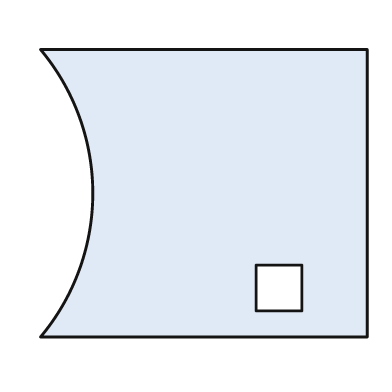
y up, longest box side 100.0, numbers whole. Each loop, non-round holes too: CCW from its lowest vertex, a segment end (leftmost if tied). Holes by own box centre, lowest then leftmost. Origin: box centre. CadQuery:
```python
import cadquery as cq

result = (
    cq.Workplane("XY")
    .moveTo(-50.0, -44.0)
    .lineTo(50.0, -44.0)
    .lineTo(50.0, 44.0)
    .lineTo(-50.0, 44.0)
    .threePointArc((-34.0, 0.0), (-50.0, -44.0))
    .close()
    .moveTo(16.0, -36.0)
    .lineTo(30.0, -36.0)
    .lineTo(30.0, -22.0)
    .lineTo(16.0, -22.0)
    .close()
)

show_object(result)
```